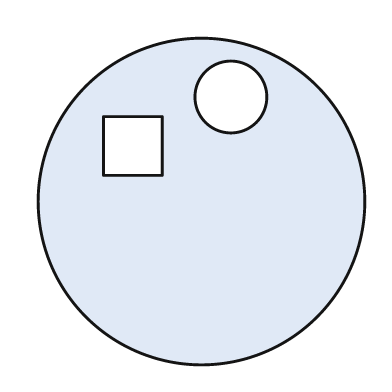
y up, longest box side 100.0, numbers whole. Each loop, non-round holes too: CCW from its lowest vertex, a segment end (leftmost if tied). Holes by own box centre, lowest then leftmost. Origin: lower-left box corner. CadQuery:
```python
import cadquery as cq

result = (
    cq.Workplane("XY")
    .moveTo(50.0, 50.0)
    .circle(50.0)
    .moveTo(20.0, 58.0)
    .lineTo(38.0, 58.0)
    .lineTo(38.0, 76.0)
    .lineTo(20.0, 76.0)
    .close()
    .moveTo(59.0, 82.0)
    .circle(11.0)
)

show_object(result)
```